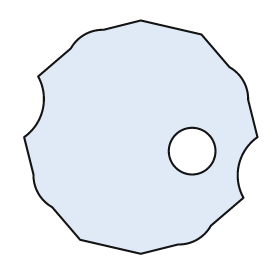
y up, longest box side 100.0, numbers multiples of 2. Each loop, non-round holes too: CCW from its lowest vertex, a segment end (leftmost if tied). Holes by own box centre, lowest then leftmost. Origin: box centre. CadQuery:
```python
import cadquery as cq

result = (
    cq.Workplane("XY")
    .moveTo(0.0, -50.0)
    .lineTo(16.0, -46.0)
    .threePointArc((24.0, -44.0), (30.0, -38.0))
    .lineTo(44.0, -26.0)
    .threePointArc((42.0, -12.0), (50.0, 0.0))
    .lineTo(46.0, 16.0)
    .threePointArc((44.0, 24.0), (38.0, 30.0))
    .lineTo(26.0, 44.0)
    .lineTo(0.0, 50.0)
    .lineTo(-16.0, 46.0)
    .threePointArc((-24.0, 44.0), (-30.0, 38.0))
    .lineTo(-44.0, 26.0)
    .threePointArc((-42.0, 12.0), (-50.0, 0.0))
    .lineTo(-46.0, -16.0)
    .threePointArc((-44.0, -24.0), (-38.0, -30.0))
    .lineTo(-26.0, -44.0)
    .close()
    .moveTo(22.0, -6.0)
    .circle(10.0)
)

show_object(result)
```